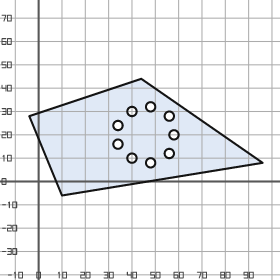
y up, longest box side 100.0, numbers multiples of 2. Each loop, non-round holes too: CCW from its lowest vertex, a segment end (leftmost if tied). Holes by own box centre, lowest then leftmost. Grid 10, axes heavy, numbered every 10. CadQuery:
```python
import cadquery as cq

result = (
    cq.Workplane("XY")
    .moveTo(10.0, -6.0)
    .lineTo(96.0, 8.0)
    .lineTo(44.0, 44.0)
    .lineTo(-4.0, 28.0)
    .close()
    .moveTo(48.0, 8.0)
    .circle(2.0)
    .moveTo(40.0, 10.0)
    .circle(2.0)
    .moveTo(56.0, 12.0)
    .circle(2.0)
    .moveTo(34.0, 16.0)
    .circle(2.0)
    .moveTo(58.0, 20.0)
    .circle(2.0)
    .moveTo(34.0, 24.0)
    .circle(2.0)
    .moveTo(56.0, 28.0)
    .circle(2.0)
    .moveTo(40.0, 30.0)
    .circle(2.0)
    .moveTo(48.0, 32.0)
    .circle(2.0)
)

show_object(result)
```